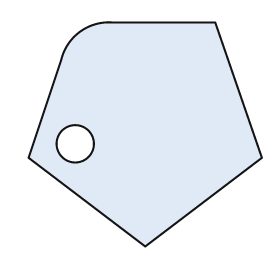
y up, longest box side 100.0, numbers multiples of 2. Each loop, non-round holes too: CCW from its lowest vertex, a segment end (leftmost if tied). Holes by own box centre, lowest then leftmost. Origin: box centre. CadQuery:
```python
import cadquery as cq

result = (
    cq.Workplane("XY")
    .moveTo(0.0, -48.0)
    .lineTo(50.0, -10.0)
    .lineTo(30.0, 48.0)
    .lineTo(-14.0, 48.0)
    .threePointArc((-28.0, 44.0), (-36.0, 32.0))
    .lineTo(-50.0, -10.0)
    .close()
    .moveTo(-30.0, -4.0)
    .circle(8.0)
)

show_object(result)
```